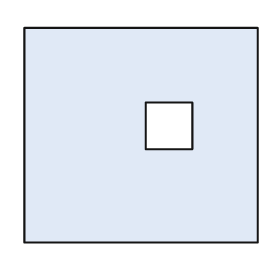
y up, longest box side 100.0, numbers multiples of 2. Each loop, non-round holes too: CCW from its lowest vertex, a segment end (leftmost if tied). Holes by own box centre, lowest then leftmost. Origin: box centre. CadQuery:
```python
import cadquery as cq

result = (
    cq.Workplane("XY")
    .moveTo(-50.0, -46.0)
    .lineTo(50.0, -46.0)
    .lineTo(50.0, 46.0)
    .lineTo(-50.0, 46.0)
    .close()
    .moveTo(2.0, -6.0)
    .lineTo(22.0, -6.0)
    .lineTo(22.0, 14.0)
    .lineTo(2.0, 14.0)
    .close()
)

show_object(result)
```